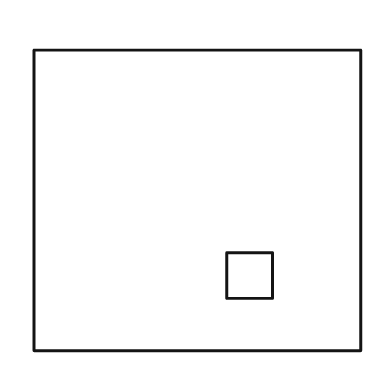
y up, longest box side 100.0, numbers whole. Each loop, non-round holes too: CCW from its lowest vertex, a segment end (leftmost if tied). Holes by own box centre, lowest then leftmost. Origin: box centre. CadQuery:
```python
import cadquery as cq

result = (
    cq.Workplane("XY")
    .moveTo(-50.0, -46.0)
    .lineTo(50.0, -46.0)
    .lineTo(50.0, 46.0)
    .lineTo(-50.0, 46.0)
    .close()
    .moveTo(9.0, -30.0)
    .lineTo(23.0, -30.0)
    .lineTo(23.0, -16.0)
    .lineTo(9.0, -16.0)
    .close()
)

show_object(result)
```